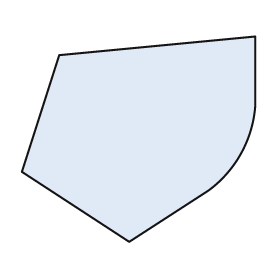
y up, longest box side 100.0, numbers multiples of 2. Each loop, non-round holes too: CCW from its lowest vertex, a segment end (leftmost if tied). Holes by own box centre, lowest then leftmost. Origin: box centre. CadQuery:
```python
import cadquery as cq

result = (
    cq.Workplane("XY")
    .moveTo(-4.0, -44.0)
    .lineTo(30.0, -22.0)
    .threePointArc((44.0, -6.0), (50.0, 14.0))
    .lineTo(50.0, 44.0)
    .lineTo(-34.0, 36.0)
    .lineTo(-50.0, -14.0)
    .close()
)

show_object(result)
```